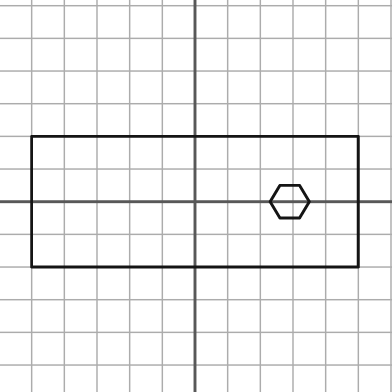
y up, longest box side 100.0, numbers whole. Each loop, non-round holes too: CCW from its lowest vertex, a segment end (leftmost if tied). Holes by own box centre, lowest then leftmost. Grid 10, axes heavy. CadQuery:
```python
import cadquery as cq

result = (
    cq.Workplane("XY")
    .moveTo(-50.0, -20.0)
    .lineTo(50.0, -20.0)
    .lineTo(50.0, 20.0)
    .lineTo(-50.0, 20.0)
    .close()
    .moveTo(26.0, -5.0)
    .lineTo(32.0, -5.0)
    .lineTo(35.0, 0.0)
    .lineTo(32.0, 5.0)
    .lineTo(26.0, 5.0)
    .lineTo(23.0, 0.0)
    .close()
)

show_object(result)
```